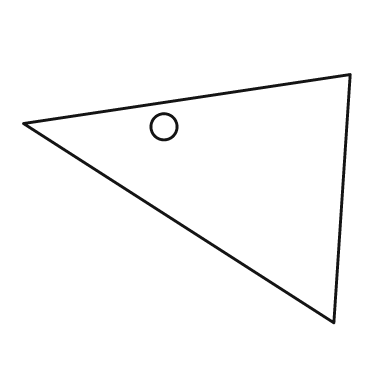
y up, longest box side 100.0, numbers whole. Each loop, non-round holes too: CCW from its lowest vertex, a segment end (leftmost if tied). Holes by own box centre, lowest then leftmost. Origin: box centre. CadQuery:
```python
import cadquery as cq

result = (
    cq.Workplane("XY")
    .moveTo(45.0, -38.0)
    .lineTo(50.0, 38.0)
    .lineTo(-50.0, 23.0)
    .close()
    .moveTo(-7.0, 22.0)
    .circle(4.0)
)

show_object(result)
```